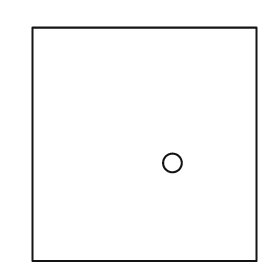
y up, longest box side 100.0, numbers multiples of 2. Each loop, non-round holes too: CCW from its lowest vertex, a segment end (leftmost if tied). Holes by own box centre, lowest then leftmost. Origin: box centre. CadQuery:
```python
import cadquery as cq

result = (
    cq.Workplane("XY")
    .moveTo(-48.0, -50.0)
    .lineTo(48.0, -50.0)
    .lineTo(48.0, 50.0)
    .lineTo(-48.0, 50.0)
    .close()
    .moveTo(12.0, -8.0)
    .circle(4.0)
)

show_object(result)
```